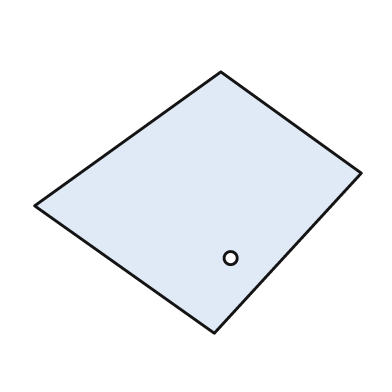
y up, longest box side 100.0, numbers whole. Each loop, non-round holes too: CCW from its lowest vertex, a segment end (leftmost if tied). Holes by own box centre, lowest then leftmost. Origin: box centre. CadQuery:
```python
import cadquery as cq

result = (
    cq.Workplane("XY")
    .moveTo(5.0, -40.0)
    .lineTo(50.0, 9.0)
    .lineTo(7.0, 40.0)
    .lineTo(-50.0, -1.0)
    .close()
    .moveTo(10.0, -17.0)
    .circle(2.0)
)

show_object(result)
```